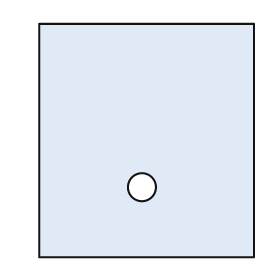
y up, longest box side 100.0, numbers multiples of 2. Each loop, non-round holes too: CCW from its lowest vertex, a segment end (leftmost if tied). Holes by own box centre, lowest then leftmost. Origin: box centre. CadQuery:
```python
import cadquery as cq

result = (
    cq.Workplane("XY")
    .moveTo(-46.0, -50.0)
    .lineTo(46.0, -50.0)
    .lineTo(46.0, 50.0)
    .lineTo(-46.0, 50.0)
    .close()
    .moveTo(-2.0, -20.0)
    .circle(6.0)
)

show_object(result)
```